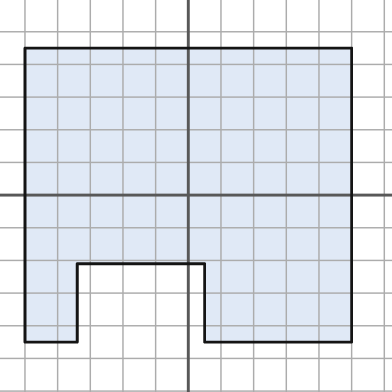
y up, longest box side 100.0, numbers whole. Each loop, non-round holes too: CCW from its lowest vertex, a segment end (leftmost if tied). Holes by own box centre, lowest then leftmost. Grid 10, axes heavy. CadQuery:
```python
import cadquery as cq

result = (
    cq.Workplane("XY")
    .moveTo(-50.0, -45.0)
    .lineTo(-34.0, -45.0)
    .lineTo(-34.0, -21.0)
    .lineTo(5.0, -21.0)
    .lineTo(5.0, -45.0)
    .lineTo(50.0, -45.0)
    .lineTo(50.0, 45.0)
    .lineTo(-50.0, 45.0)
    .close()
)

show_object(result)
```